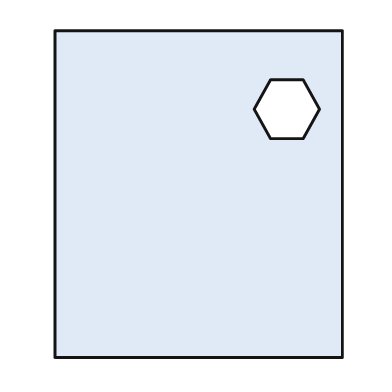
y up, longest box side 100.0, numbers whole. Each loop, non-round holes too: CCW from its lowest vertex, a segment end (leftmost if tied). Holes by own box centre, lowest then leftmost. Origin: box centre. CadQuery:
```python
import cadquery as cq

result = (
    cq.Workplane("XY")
    .moveTo(-44.0, -50.0)
    .lineTo(44.0, -50.0)
    .lineTo(44.0, 50.0)
    .lineTo(-44.0, 50.0)
    .close()
    .moveTo(22.0, 17.0)
    .lineTo(32.0, 17.0)
    .lineTo(37.0, 26.0)
    .lineTo(32.0, 35.0)
    .lineTo(22.0, 35.0)
    .lineTo(17.0, 26.0)
    .close()
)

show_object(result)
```